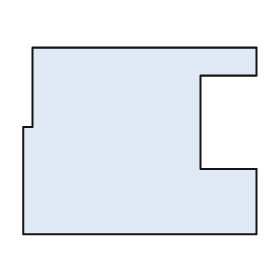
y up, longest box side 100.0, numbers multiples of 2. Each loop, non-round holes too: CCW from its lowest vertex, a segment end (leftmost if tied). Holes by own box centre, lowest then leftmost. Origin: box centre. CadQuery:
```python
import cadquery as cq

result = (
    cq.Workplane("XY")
    .moveTo(-50.0, -40.0)
    .lineTo(50.0, -40.0)
    .lineTo(50.0, -12.0)
    .lineTo(26.0, -12.0)
    .lineTo(26.0, 28.0)
    .lineTo(50.0, 28.0)
    .lineTo(50.0, 40.0)
    .lineTo(-46.0, 40.0)
    .lineTo(-46.0, 6.0)
    .lineTo(-50.0, 6.0)
    .close()
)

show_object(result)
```